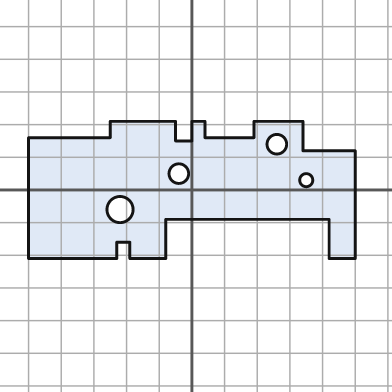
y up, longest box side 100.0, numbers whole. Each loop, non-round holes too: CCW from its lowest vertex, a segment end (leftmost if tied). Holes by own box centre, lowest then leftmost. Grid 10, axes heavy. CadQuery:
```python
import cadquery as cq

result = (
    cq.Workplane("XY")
    .moveTo(-50.0, -21.0)
    .lineTo(-23.0, -21.0)
    .lineTo(-23.0, -16.0)
    .lineTo(-19.0, -16.0)
    .lineTo(-19.0, -21.0)
    .lineTo(-8.0, -21.0)
    .lineTo(-8.0, -9.0)
    .lineTo(42.0, -9.0)
    .lineTo(42.0, -21.0)
    .lineTo(50.0, -21.0)
    .lineTo(50.0, 12.0)
    .lineTo(34.0, 12.0)
    .lineTo(34.0, 21.0)
    .lineTo(19.0, 21.0)
    .lineTo(19.0, 16.0)
    .lineTo(4.0, 16.0)
    .lineTo(4.0, 21.0)
    .lineTo(0.0, 21.0)
    .lineTo(0.0, 15.0)
    .lineTo(-5.0, 15.0)
    .lineTo(-5.0, 21.0)
    .lineTo(-25.0, 21.0)
    .lineTo(-25.0, 16.0)
    .lineTo(-50.0, 16.0)
    .close()
    .moveTo(-22.0, -6.0)
    .circle(4.0)
    .moveTo(35.0, 3.0)
    .circle(2.0)
    .moveTo(-4.0, 5.0)
    .circle(3.0)
    .moveTo(26.0, 14.0)
    .circle(3.0)
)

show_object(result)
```